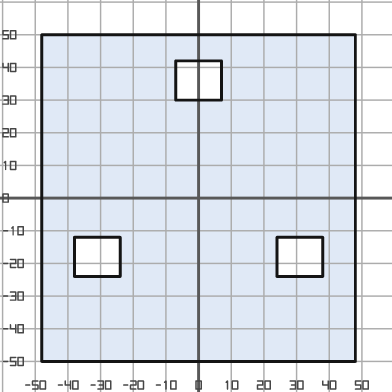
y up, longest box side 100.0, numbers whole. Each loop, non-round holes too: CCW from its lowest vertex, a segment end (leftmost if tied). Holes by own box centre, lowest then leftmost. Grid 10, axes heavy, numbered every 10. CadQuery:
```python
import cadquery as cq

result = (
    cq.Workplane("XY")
    .moveTo(-48.0, -50.0)
    .lineTo(48.0, -50.0)
    .lineTo(48.0, 50.0)
    .lineTo(-48.0, 50.0)
    .close()
    .moveTo(-38.0, -24.0)
    .lineTo(-24.0, -24.0)
    .lineTo(-24.0, -12.0)
    .lineTo(-38.0, -12.0)
    .close()
    .moveTo(24.0, -24.0)
    .lineTo(38.0, -24.0)
    .lineTo(38.0, -12.0)
    .lineTo(24.0, -12.0)
    .close()
    .moveTo(-7.0, 30.0)
    .lineTo(7.0, 30.0)
    .lineTo(7.0, 42.0)
    .lineTo(-7.0, 42.0)
    .close()
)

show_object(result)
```